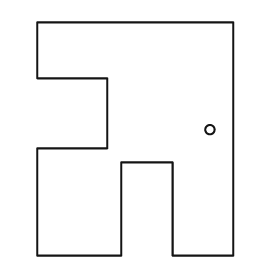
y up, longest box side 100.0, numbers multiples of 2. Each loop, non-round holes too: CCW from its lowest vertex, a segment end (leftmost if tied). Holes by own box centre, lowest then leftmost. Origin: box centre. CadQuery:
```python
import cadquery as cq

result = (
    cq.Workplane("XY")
    .moveTo(-42.0, -50.0)
    .lineTo(-6.0, -50.0)
    .lineTo(-6.0, -10.0)
    .lineTo(16.0, -10.0)
    .lineTo(16.0, -50.0)
    .lineTo(42.0, -50.0)
    .lineTo(42.0, 50.0)
    .lineTo(-42.0, 50.0)
    .lineTo(-42.0, 26.0)
    .lineTo(-12.0, 26.0)
    .lineTo(-12.0, -4.0)
    .lineTo(-42.0, -4.0)
    .close()
    .moveTo(32.0, 4.0)
    .circle(2.0)
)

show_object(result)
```